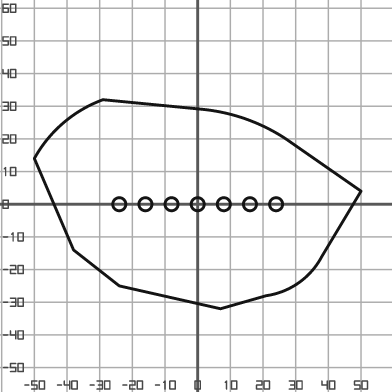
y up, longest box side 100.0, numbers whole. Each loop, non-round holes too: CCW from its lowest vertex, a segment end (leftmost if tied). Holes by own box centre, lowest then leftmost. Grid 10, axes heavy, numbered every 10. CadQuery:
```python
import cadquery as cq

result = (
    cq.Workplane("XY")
    .moveTo(7.0, -32.0)
    .lineTo(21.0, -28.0)
    .threePointArc((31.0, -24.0), (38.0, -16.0))
    .lineTo(50.0, 4.0)
    .lineTo(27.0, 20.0)
    .threePointArc((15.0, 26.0), (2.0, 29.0))
    .lineTo(-29.0, 32.0)
    .threePointArc((-41.0, 25.0), (-50.0, 14.0))
    .lineTo(-38.0, -14.0)
    .lineTo(-24.0, -25.0)
    .close()
    .moveTo(-24.0, 0.0)
    .circle(2.0)
    .moveTo(-16.0, 0.0)
    .circle(2.0)
    .moveTo(-8.0, 0.0)
    .circle(2.0)
    .moveTo(0.0, 0.0)
    .circle(2.0)
    .moveTo(8.0, 0.0)
    .circle(2.0)
    .moveTo(16.0, 0.0)
    .circle(2.0)
    .moveTo(24.0, 0.0)
    .circle(2.0)
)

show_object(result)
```